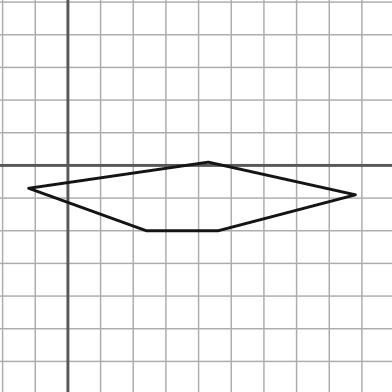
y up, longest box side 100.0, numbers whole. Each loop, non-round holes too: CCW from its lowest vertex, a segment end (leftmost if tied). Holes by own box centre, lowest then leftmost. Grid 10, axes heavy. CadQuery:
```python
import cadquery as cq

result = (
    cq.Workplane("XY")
    .moveTo(24.0, -20.0)
    .lineTo(46.0, -20.0)
    .lineTo(88.0, -9.0)
    .lineTo(43.0, 1.0)
    .lineTo(-12.0, -7.0)
    .close()
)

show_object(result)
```